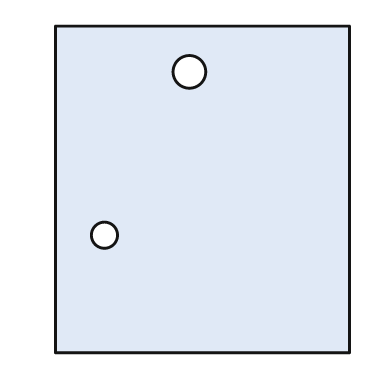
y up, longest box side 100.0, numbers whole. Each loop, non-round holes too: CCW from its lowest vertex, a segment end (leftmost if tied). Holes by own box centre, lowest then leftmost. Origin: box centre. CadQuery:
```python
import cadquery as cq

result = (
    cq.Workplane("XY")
    .moveTo(-45.0, -50.0)
    .lineTo(45.0, -50.0)
    .lineTo(45.0, 50.0)
    .lineTo(-45.0, 50.0)
    .close()
    .moveTo(-30.0, -14.0)
    .circle(4.0)
    .moveTo(-4.0, 36.0)
    .circle(5.0)
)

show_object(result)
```